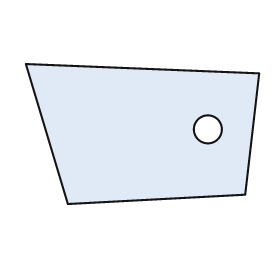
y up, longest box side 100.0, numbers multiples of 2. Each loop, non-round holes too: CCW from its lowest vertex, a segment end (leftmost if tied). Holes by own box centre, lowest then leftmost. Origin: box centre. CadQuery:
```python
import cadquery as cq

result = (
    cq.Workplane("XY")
    .moveTo(-32.0, -30.0)
    .lineTo(44.0, -26.0)
    .lineTo(50.0, 26.0)
    .lineTo(-50.0, 30.0)
    .close()
    .moveTo(28.0, 2.0)
    .circle(6.0)
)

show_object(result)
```